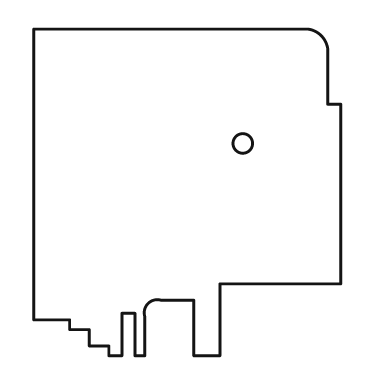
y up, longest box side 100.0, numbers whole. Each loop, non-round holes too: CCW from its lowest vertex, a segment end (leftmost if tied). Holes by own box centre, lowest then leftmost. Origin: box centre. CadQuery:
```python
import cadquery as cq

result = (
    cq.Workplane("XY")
    .moveTo(-24.0, -50.0)
    .lineTo(-20.0, -50.0)
    .lineTo(-20.0, -37.0)
    .lineTo(-16.0, -37.0)
    .lineTo(-16.0, -50.0)
    .lineTo(-13.0, -50.0)
    .lineTo(-13.0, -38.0)
    .threePointArc((-12.0, -34.0), (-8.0, -33.0))
    .lineTo(2.0, -33.0)
    .lineTo(2.0, -50.0)
    .lineTo(10.0, -50.0)
    .lineTo(10.0, -28.0)
    .lineTo(47.0, -28.0)
    .lineTo(47.0, 27.0)
    .lineTo(43.0, 27.0)
    .lineTo(43.0, 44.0)
    .threePointArc((41.0, 48.0), (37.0, 50.0))
    .lineTo(-47.0, 50.0)
    .lineTo(-47.0, -39.0)
    .lineTo(-36.0, -39.0)
    .lineTo(-36.0, -42.0)
    .lineTo(-30.0, -42.0)
    .lineTo(-30.0, -47.0)
    .lineTo(-24.0, -47.0)
    .close()
    .moveTo(17.0, 15.0)
    .circle(3.0)
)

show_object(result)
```